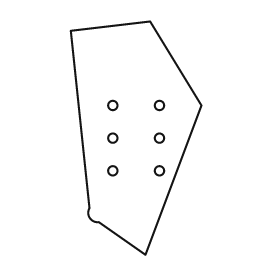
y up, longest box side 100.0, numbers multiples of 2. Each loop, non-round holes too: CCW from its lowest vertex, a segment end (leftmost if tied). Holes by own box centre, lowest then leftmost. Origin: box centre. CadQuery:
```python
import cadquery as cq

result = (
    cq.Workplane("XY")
    .moveTo(4.0, -50.0)
    .lineTo(28.0, 14.0)
    .lineTo(6.0, 50.0)
    .lineTo(-28.0, 46.0)
    .lineTo(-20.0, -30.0)
    .threePointArc((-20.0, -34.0), (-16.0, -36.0))
    .close()
    .moveTo(-10.0, -14.0)
    .circle(2.0)
    .moveTo(10.0, -14.0)
    .circle(2.0)
    .moveTo(-10.0, 0.0)
    .circle(2.0)
    .moveTo(10.0, 0.0)
    .circle(2.0)
    .moveTo(-10.0, 14.0)
    .circle(2.0)
    .moveTo(10.0, 14.0)
    .circle(2.0)
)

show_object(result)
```